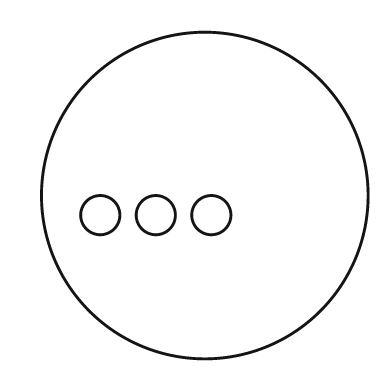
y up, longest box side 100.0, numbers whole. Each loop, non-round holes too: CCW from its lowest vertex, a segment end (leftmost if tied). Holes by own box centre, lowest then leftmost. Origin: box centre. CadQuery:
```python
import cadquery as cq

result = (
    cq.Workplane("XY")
    .moveTo(0.0, 0.0)
    .circle(50.0)
    .moveTo(-32.0, -6.0)
    .circle(6.0)
    .moveTo(-15.0, -6.0)
    .circle(6.0)
    .moveTo(2.0, -6.0)
    .circle(6.0)
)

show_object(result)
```